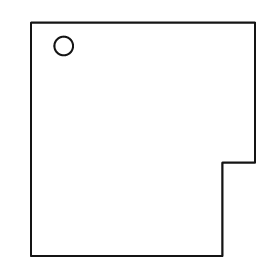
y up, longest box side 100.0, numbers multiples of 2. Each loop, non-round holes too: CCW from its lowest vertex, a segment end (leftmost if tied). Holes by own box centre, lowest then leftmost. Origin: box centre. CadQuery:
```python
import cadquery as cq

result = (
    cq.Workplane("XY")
    .moveTo(-48.0, -50.0)
    .lineTo(34.0, -50.0)
    .lineTo(34.0, -10.0)
    .lineTo(48.0, -10.0)
    .lineTo(48.0, 50.0)
    .lineTo(-48.0, 50.0)
    .close()
    .moveTo(-34.0, 40.0)
    .circle(4.0)
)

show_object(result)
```